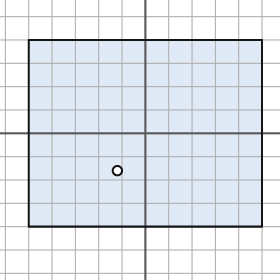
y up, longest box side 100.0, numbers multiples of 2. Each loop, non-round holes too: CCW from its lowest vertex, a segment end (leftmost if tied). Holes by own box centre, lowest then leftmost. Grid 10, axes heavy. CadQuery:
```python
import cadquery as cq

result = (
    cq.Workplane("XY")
    .moveTo(-50.0, -40.0)
    .lineTo(50.0, -40.0)
    .lineTo(50.0, 40.0)
    .lineTo(-50.0, 40.0)
    .close()
    .moveTo(-12.0, -16.0)
    .circle(2.0)
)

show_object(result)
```